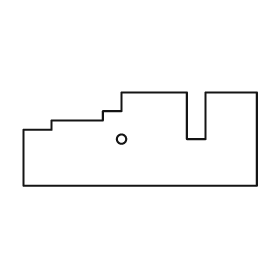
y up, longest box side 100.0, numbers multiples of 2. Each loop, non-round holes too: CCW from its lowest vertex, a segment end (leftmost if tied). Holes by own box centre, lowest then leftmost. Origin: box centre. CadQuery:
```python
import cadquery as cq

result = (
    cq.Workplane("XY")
    .moveTo(-50.0, -20.0)
    .lineTo(50.0, -20.0)
    .lineTo(50.0, 20.0)
    .lineTo(28.0, 20.0)
    .lineTo(28.0, 0.0)
    .lineTo(20.0, 0.0)
    .lineTo(20.0, 20.0)
    .lineTo(-8.0, 20.0)
    .lineTo(-8.0, 12.0)
    .lineTo(-16.0, 12.0)
    .lineTo(-16.0, 8.0)
    .lineTo(-38.0, 8.0)
    .lineTo(-38.0, 4.0)
    .lineTo(-50.0, 4.0)
    .close()
    .moveTo(-8.0, 0.0)
    .circle(2.0)
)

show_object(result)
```